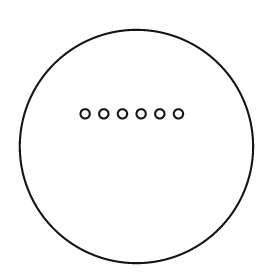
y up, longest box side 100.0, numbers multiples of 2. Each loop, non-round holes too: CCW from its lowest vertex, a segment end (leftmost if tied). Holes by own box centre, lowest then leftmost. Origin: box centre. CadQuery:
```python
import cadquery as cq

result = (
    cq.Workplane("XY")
    .moveTo(0.0, 0.0)
    .circle(50.0)
    .moveTo(-22.0, 14.0)
    .circle(2.0)
    .moveTo(-14.0, 14.0)
    .circle(2.0)
    .moveTo(-6.0, 14.0)
    .circle(2.0)
    .moveTo(2.0, 14.0)
    .circle(2.0)
    .moveTo(10.0, 14.0)
    .circle(2.0)
    .moveTo(18.0, 14.0)
    .circle(2.0)
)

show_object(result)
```